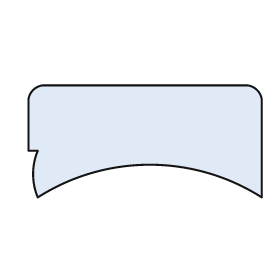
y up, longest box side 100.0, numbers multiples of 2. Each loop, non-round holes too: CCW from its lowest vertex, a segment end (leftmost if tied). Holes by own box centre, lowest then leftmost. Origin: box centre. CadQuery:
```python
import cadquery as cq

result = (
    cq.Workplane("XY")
    .moveTo(-46.0, -24.0)
    .threePointArc((2.0, -10.0), (50.0, -24.0))
    .lineTo(50.0, 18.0)
    .threePointArc((48.0, 22.0), (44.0, 24.0))
    .lineTo(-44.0, 24.0)
    .threePointArc((-48.0, 22.0), (-50.0, 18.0))
    .lineTo(-50.0, -4.0)
    .lineTo(-46.0, -4.0)
    .threePointArc((-48.0, -14.0), (-46.0, -24.0))
    .close()
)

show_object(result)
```